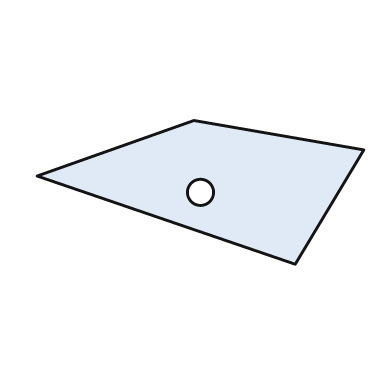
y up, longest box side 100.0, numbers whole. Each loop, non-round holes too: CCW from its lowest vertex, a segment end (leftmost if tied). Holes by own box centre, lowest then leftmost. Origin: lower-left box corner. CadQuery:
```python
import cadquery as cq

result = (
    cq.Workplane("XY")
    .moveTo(79.0, 0.0)
    .lineTo(100.0, 35.0)
    .lineTo(48.0, 44.0)
    .lineTo(0.0, 27.0)
    .close()
    .moveTo(50.0, 22.0)
    .circle(4.0)
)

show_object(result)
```